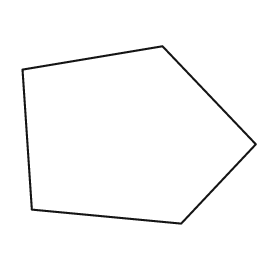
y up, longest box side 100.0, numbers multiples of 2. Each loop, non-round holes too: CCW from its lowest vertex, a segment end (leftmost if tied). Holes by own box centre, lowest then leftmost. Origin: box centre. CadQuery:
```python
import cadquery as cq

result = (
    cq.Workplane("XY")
    .moveTo(18.0, -38.0)
    .lineTo(50.0, -4.0)
    .lineTo(10.0, 38.0)
    .lineTo(-50.0, 28.0)
    .lineTo(-46.0, -32.0)
    .close()
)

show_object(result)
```